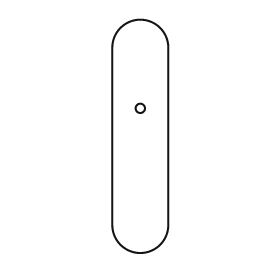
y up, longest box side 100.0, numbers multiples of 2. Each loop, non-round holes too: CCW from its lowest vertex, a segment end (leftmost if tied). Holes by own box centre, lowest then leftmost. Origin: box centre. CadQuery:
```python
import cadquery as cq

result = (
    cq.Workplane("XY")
    .moveTo(-12.0, -38.0)
    .threePointArc((0.0, -50.0), (12.0, -38.0))
    .lineTo(12.0, 38.0)
    .threePointArc((0.0, 50.0), (-12.0, 38.0))
    .close()
    .moveTo(0.0, 12.0)
    .circle(2.0)
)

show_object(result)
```